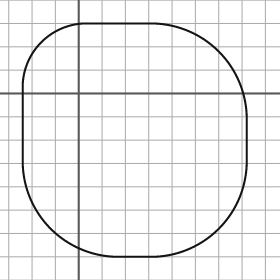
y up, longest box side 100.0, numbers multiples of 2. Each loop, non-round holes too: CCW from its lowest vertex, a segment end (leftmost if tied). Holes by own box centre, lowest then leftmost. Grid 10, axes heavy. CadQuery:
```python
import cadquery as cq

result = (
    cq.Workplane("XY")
    .moveTo(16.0, -70.0)
    .lineTo(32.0, -70.0)
    .threePointArc((60.0, -58.0), (72.0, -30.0))
    .lineTo(72.0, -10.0)
    .threePointArc((60.0, 18.0), (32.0, 30.0))
    .lineTo(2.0, 30.0)
    .threePointArc((-16.0, 22.0), (-24.0, 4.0))
    .lineTo(-24.0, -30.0)
    .threePointArc((-12.0, -58.0), (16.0, -70.0))
    .close()
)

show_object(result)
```